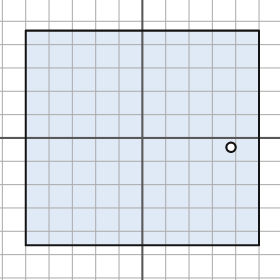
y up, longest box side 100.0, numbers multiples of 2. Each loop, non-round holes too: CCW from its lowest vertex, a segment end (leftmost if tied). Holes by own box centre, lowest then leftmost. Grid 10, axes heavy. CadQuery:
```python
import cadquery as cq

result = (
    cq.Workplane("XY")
    .moveTo(-50.0, -46.0)
    .lineTo(50.0, -46.0)
    .lineTo(50.0, 46.0)
    .lineTo(-50.0, 46.0)
    .close()
    .moveTo(38.0, -4.0)
    .circle(2.0)
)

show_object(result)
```